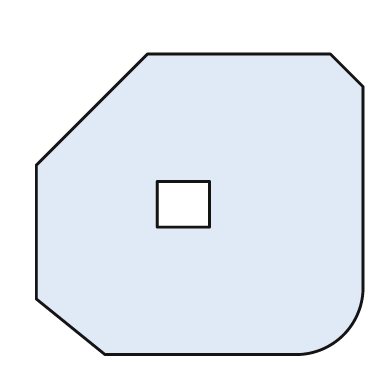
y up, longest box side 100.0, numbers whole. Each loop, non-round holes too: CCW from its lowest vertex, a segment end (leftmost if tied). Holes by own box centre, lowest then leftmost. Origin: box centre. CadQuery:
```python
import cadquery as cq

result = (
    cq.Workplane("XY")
    .moveTo(-29.0, -46.0)
    .lineTo(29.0, -46.0)
    .threePointArc((44.0, -40.0), (50.0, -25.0))
    .lineTo(50.0, 36.0)
    .lineTo(40.0, 46.0)
    .lineTo(-16.0, 46.0)
    .lineTo(-50.0, 12.0)
    .lineTo(-50.0, -29.0)
    .close()
    .moveTo(-13.0, -7.0)
    .lineTo(3.0, -7.0)
    .lineTo(3.0, 7.0)
    .lineTo(-13.0, 7.0)
    .close()
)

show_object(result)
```